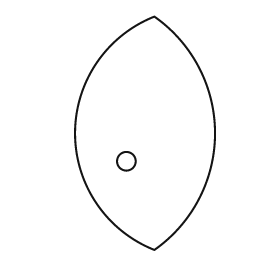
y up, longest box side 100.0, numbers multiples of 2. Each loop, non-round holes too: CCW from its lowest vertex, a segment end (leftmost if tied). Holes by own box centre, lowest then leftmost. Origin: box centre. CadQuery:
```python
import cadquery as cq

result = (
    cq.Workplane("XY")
    .moveTo(4.0, -50.0)
    .threePointArc((30.0, 0.0), (4.0, 50.0))
    .threePointArc((-30.0, 0.0), (4.0, -50.0))
    .close()
    .moveTo(-8.0, -12.0)
    .circle(4.0)
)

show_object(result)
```